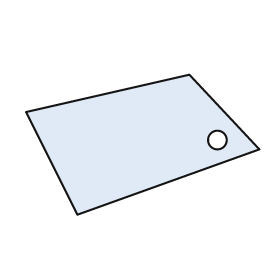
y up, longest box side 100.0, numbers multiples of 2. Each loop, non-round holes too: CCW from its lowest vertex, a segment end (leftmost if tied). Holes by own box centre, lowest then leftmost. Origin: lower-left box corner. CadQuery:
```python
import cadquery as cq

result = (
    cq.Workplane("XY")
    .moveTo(22.0, 0.0)
    .lineTo(100.0, 28.0)
    .lineTo(70.0, 60.0)
    .lineTo(0.0, 44.0)
    .close()
    .moveTo(82.0, 32.0)
    .circle(4.0)
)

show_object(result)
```